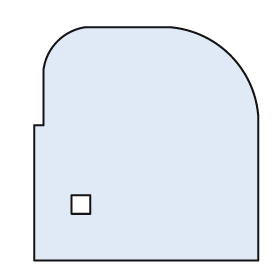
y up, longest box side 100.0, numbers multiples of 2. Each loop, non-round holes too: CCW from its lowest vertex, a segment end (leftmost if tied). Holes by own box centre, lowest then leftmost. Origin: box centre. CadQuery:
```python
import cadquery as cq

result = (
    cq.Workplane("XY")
    .moveTo(-48.0, -50.0)
    .lineTo(48.0, -50.0)
    .lineTo(48.0, 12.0)
    .threePointArc((36.0, 38.0), (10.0, 50.0))
    .lineTo(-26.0, 50.0)
    .threePointArc((-38.0, 44.0), (-44.0, 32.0))
    .lineTo(-44.0, 8.0)
    .lineTo(-48.0, 8.0)
    .close()
    .moveTo(-32.0, -30.0)
    .lineTo(-24.0, -30.0)
    .lineTo(-24.0, -22.0)
    .lineTo(-32.0, -22.0)
    .close()
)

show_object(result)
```